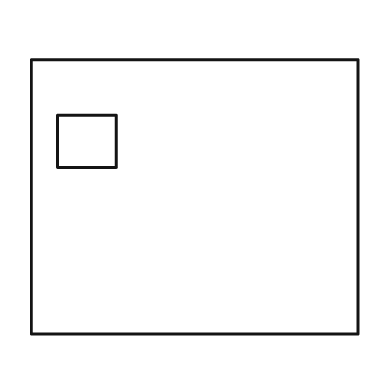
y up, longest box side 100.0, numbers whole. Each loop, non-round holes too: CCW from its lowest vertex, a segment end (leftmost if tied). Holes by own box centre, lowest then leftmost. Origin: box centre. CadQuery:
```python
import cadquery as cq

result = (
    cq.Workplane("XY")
    .moveTo(-50.0, -42.0)
    .lineTo(50.0, -42.0)
    .lineTo(50.0, 42.0)
    .lineTo(-50.0, 42.0)
    .close()
    .moveTo(-42.0, 9.0)
    .lineTo(-24.0, 9.0)
    .lineTo(-24.0, 25.0)
    .lineTo(-42.0, 25.0)
    .close()
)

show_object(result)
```